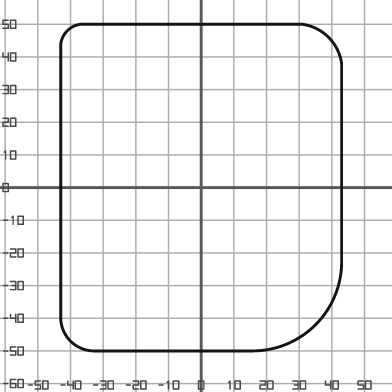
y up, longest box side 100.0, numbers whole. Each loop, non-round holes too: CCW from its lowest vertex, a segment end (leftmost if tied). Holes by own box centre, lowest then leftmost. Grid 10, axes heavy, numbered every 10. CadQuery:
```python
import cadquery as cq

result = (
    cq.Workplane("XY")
    .moveTo(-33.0, -50.0)
    .lineTo(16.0, -50.0)
    .threePointArc((35.0, -42.0), (43.0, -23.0))
    .lineTo(43.0, 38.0)
    .threePointArc((39.0, 46.0), (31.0, 50.0))
    .lineTo(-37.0, 50.0)
    .threePointArc((-41.0, 48.0), (-43.0, 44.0))
    .lineTo(-43.0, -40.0)
    .threePointArc((-40.0, -47.0), (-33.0, -50.0))
    .close()
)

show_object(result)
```